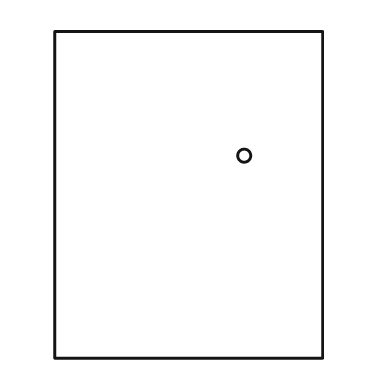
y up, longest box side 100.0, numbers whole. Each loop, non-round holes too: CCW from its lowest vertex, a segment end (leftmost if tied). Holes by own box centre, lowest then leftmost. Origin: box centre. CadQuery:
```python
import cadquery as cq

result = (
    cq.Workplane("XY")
    .moveTo(-41.0, -50.0)
    .lineTo(41.0, -50.0)
    .lineTo(41.0, 50.0)
    .lineTo(-41.0, 50.0)
    .close()
    .moveTo(17.0, 12.0)
    .circle(2.0)
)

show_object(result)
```